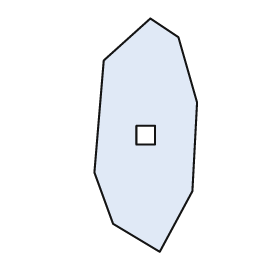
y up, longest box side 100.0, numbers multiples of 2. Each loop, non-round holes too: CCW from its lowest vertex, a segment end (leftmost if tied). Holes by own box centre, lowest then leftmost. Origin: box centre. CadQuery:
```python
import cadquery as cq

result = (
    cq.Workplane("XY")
    .moveTo(6.0, -50.0)
    .lineTo(20.0, -24.0)
    .lineTo(22.0, 14.0)
    .lineTo(14.0, 42.0)
    .lineTo(2.0, 50.0)
    .lineTo(-18.0, 32.0)
    .lineTo(-22.0, -16.0)
    .lineTo(-14.0, -38.0)
    .close()
    .moveTo(-4.0, -4.0)
    .lineTo(4.0, -4.0)
    .lineTo(4.0, 4.0)
    .lineTo(-4.0, 4.0)
    .close()
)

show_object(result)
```